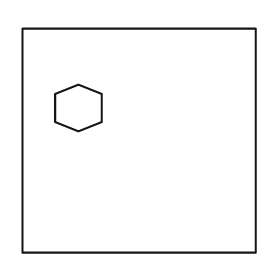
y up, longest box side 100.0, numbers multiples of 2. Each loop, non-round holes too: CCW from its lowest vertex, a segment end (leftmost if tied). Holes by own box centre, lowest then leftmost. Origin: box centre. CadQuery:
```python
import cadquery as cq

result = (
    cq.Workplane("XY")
    .moveTo(-50.0, -48.0)
    .lineTo(50.0, -48.0)
    .lineTo(50.0, 48.0)
    .lineTo(-50.0, 48.0)
    .close()
    .moveTo(-26.0, 4.0)
    .lineTo(-16.0, 8.0)
    .lineTo(-16.0, 20.0)
    .lineTo(-26.0, 24.0)
    .lineTo(-36.0, 20.0)
    .lineTo(-36.0, 8.0)
    .close()
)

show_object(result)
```